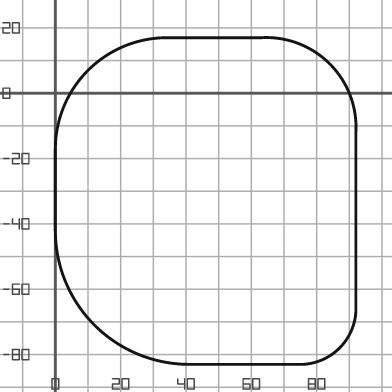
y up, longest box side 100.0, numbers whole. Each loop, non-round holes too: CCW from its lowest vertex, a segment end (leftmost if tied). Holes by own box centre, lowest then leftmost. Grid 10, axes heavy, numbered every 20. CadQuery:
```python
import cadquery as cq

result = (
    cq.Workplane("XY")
    .moveTo(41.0, -83.0)
    .lineTo(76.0, -83.0)
    .threePointArc((87.0, -78.0), (92.0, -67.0))
    .lineTo(92.0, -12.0)
    .threePointArc((84.0, 9.0), (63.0, 17.0))
    .lineTo(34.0, 17.0)
    .threePointArc((10.0, 7.0), (0.0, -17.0))
    .lineTo(0.0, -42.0)
    .threePointArc((12.0, -71.0), (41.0, -83.0))
    .close()
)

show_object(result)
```